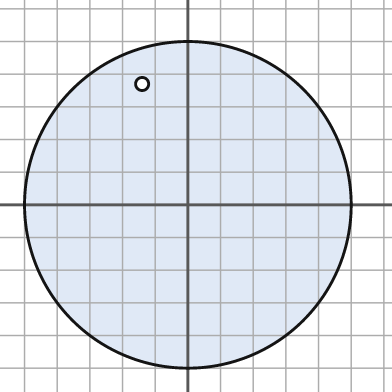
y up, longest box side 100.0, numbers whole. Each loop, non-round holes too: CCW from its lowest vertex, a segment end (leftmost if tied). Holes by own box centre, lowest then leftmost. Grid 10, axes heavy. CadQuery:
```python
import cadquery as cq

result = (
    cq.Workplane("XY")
    .moveTo(0.0, 0.0)
    .circle(50.0)
    .moveTo(-14.0, 37.0)
    .circle(2.0)
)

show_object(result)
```